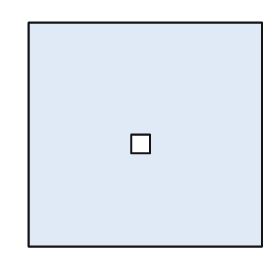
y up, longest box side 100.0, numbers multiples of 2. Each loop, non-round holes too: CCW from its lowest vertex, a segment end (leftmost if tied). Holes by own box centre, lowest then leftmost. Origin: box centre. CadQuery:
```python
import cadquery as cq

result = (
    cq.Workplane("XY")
    .moveTo(-50.0, -48.0)
    .lineTo(50.0, -48.0)
    .lineTo(50.0, 48.0)
    .lineTo(-50.0, 48.0)
    .close()
    .moveTo(-6.0, -8.0)
    .lineTo(2.0, -8.0)
    .lineTo(2.0, 0.0)
    .lineTo(-6.0, 0.0)
    .close()
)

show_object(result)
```